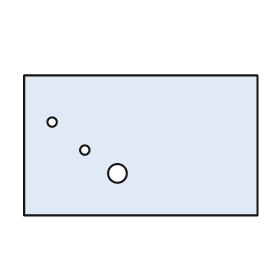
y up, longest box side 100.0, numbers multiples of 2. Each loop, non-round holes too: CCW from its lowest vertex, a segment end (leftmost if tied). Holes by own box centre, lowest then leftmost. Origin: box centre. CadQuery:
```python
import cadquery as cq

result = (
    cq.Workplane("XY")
    .moveTo(-50.0, -30.0)
    .lineTo(50.0, -30.0)
    .lineTo(50.0, 30.0)
    .lineTo(-50.0, 30.0)
    .close()
    .moveTo(-10.0, -12.0)
    .circle(4.0)
    .moveTo(-24.0, -2.0)
    .circle(2.0)
    .moveTo(-38.0, 10.0)
    .circle(2.0)
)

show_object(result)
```